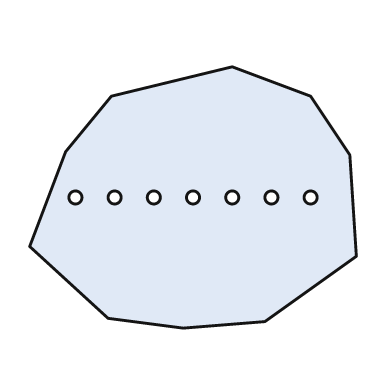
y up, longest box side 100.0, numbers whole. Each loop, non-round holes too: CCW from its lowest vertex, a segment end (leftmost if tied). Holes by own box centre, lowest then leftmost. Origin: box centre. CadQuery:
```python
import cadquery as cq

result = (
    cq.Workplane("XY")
    .moveTo(-3.0, -40.0)
    .lineTo(22.0, -38.0)
    .lineTo(50.0, -18.0)
    .lineTo(48.0, 13.0)
    .lineTo(36.0, 31.0)
    .lineTo(12.0, 40.0)
    .lineTo(-25.0, 31.0)
    .lineTo(-39.0, 14.0)
    .lineTo(-50.0, -15.0)
    .lineTo(-26.0, -37.0)
    .close()
    .moveTo(-36.0, 0.0)
    .circle(2.0)
    .moveTo(-24.0, 0.0)
    .circle(2.0)
    .moveTo(-12.0, 0.0)
    .circle(2.0)
    .moveTo(0.0, 0.0)
    .circle(2.0)
    .moveTo(12.0, 0.0)
    .circle(2.0)
    .moveTo(24.0, 0.0)
    .circle(2.0)
    .moveTo(36.0, 0.0)
    .circle(2.0)
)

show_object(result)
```